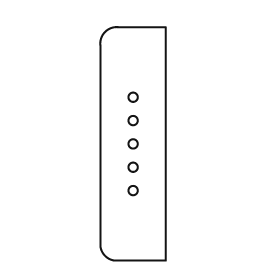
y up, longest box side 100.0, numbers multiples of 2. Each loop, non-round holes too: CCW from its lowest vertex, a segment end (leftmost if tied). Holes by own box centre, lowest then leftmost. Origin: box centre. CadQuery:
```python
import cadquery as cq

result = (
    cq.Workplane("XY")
    .moveTo(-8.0, -50.0)
    .lineTo(14.0, -50.0)
    .lineTo(14.0, 50.0)
    .lineTo(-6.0, 50.0)
    .threePointArc((-12.0, 48.0), (-14.0, 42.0))
    .lineTo(-14.0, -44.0)
    .threePointArc((-12.0, -48.0), (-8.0, -50.0))
    .close()
    .moveTo(0.0, -20.0)
    .circle(2.0)
    .moveTo(0.0, -10.0)
    .circle(2.0)
    .moveTo(0.0, 0.0)
    .circle(2.0)
    .moveTo(0.0, 10.0)
    .circle(2.0)
    .moveTo(0.0, 20.0)
    .circle(2.0)
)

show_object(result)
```